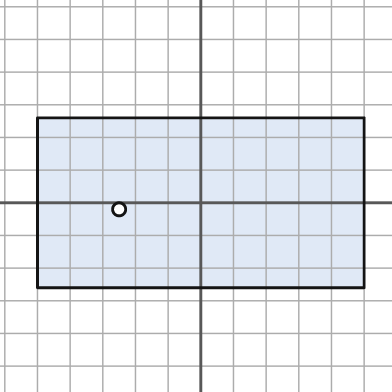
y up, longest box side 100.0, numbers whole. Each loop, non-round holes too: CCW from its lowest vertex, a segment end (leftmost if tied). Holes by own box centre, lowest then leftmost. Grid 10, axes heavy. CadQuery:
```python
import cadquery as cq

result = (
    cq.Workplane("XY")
    .moveTo(-50.0, -26.0)
    .lineTo(50.0, -26.0)
    .lineTo(50.0, 26.0)
    .lineTo(-50.0, 26.0)
    .close()
    .moveTo(-25.0, -2.0)
    .circle(2.0)
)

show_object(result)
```